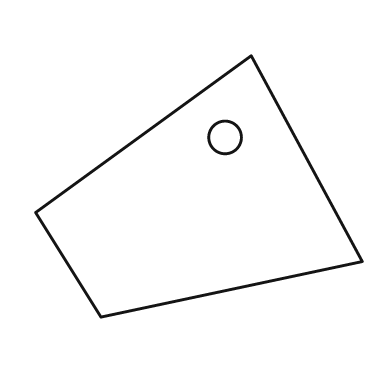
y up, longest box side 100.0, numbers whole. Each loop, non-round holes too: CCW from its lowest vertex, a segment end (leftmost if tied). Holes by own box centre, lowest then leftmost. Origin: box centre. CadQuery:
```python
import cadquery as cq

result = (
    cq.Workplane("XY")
    .moveTo(-30.0, -40.0)
    .lineTo(50.0, -23.0)
    .lineTo(16.0, 40.0)
    .lineTo(-50.0, -8.0)
    .close()
    .moveTo(8.0, 15.0)
    .circle(5.0)
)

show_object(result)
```